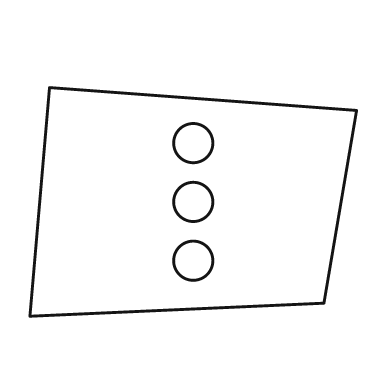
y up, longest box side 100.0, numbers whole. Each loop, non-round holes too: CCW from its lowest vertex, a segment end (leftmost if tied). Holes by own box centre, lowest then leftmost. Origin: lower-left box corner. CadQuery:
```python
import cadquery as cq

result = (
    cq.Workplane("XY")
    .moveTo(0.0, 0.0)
    .lineTo(90.0, 4.0)
    .lineTo(100.0, 63.0)
    .lineTo(6.0, 70.0)
    .close()
    .moveTo(50.0, 17.0)
    .circle(6.0)
    .moveTo(50.0, 35.0)
    .circle(6.0)
    .moveTo(50.0, 53.0)
    .circle(6.0)
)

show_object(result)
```